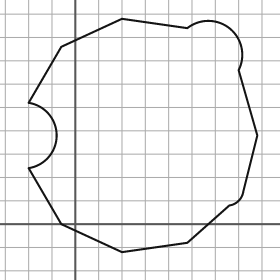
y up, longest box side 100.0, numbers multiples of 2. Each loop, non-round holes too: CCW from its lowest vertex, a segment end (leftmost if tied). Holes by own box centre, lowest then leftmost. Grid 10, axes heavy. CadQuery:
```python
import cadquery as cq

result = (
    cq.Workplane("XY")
    .moveTo(20.0, -12.0)
    .lineTo(48.0, -8.0)
    .lineTo(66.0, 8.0)
    .threePointArc((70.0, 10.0), (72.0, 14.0))
    .lineTo(78.0, 38.0)
    .lineTo(70.0, 66.0)
    .threePointArc((66.0, 84.0), (48.0, 84.0))
    .lineTo(20.0, 88.0)
    .lineTo(-6.0, 76.0)
    .lineTo(-20.0, 52.0)
    .threePointArc((-8.0, 38.0), (-20.0, 24.0))
    .lineTo(-6.0, 0.0)
    .close()
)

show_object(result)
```